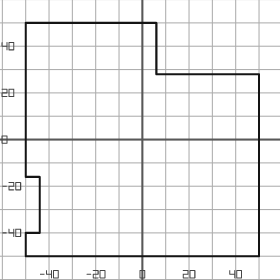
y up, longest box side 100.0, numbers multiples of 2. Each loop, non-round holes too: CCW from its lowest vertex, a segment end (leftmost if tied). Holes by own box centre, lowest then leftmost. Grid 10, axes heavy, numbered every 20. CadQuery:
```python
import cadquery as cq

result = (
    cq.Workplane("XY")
    .moveTo(-50.0, -50.0)
    .lineTo(50.0, -50.0)
    .lineTo(50.0, 28.0)
    .lineTo(6.0, 28.0)
    .lineTo(6.0, 50.0)
    .lineTo(-50.0, 50.0)
    .lineTo(-50.0, -16.0)
    .lineTo(-44.0, -16.0)
    .lineTo(-44.0, -40.0)
    .lineTo(-50.0, -40.0)
    .close()
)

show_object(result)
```